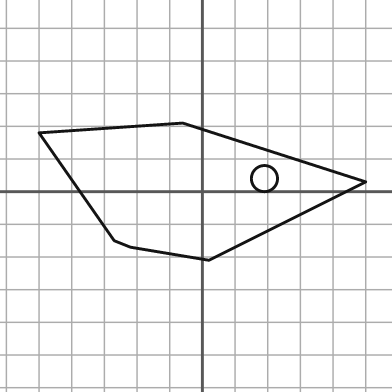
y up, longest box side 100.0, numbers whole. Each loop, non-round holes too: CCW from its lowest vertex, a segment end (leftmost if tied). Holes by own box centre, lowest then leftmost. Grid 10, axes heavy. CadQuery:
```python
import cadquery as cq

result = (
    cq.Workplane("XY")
    .moveTo(2.0, -21.0)
    .lineTo(50.0, 3.0)
    .lineTo(-6.0, 21.0)
    .lineTo(-50.0, 18.0)
    .lineTo(-27.0, -15.0)
    .lineTo(-22.0, -17.0)
    .close()
    .moveTo(19.0, 4.0)
    .circle(4.0)
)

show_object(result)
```